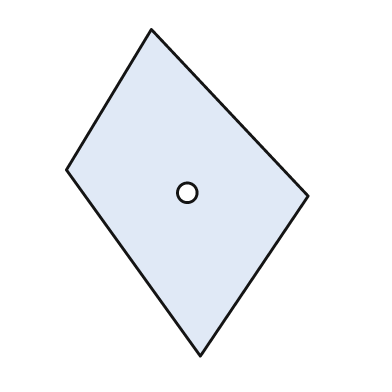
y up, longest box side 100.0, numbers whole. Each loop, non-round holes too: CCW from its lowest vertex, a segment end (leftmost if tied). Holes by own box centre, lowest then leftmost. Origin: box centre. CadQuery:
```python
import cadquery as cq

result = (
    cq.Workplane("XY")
    .moveTo(4.0, -50.0)
    .lineTo(37.0, -1.0)
    .lineTo(-11.0, 50.0)
    .lineTo(-37.0, 7.0)
    .close()
    .moveTo(0.0, 0.0)
    .circle(3.0)
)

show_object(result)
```